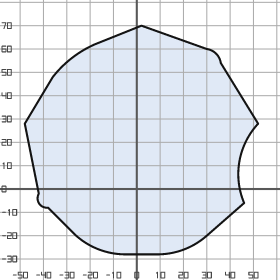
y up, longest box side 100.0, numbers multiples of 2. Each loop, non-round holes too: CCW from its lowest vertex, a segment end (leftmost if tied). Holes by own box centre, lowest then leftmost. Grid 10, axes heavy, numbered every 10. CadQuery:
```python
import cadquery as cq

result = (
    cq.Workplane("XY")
    .moveTo(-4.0, -28.0)
    .lineTo(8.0, -28.0)
    .threePointArc((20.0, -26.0), (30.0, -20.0))
    .lineTo(46.0, -6.0)
    .threePointArc((44.0, 12.0), (52.0, 28.0))
    .lineTo(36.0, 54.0)
    .threePointArc((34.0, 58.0), (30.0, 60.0))
    .lineTo(2.0, 70.0)
    .lineTo(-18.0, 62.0)
    .threePointArc((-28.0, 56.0), (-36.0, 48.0))
    .lineTo(-48.0, 28.0)
    .lineTo(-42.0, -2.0)
    .threePointArc((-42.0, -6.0), (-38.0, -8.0))
    .lineTo(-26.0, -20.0)
    .threePointArc((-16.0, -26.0), (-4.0, -28.0))
    .close()
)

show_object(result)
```